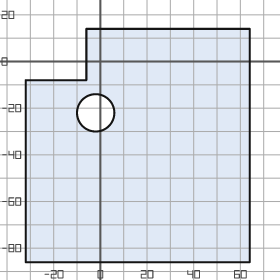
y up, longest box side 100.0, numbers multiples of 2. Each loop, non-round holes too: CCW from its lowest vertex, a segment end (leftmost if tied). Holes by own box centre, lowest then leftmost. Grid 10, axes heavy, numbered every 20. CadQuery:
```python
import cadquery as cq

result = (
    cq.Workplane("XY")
    .moveTo(-32.0, -86.0)
    .lineTo(64.0, -86.0)
    .lineTo(64.0, 14.0)
    .lineTo(-6.0, 14.0)
    .lineTo(-6.0, -8.0)
    .lineTo(-32.0, -8.0)
    .close()
    .moveTo(-2.0, -22.0)
    .circle(8.0)
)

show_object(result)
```